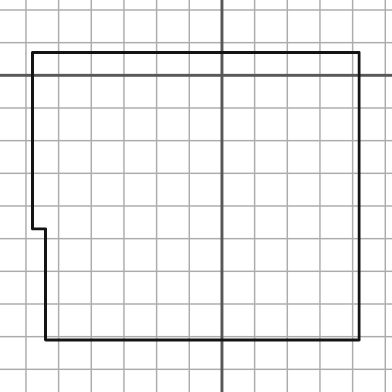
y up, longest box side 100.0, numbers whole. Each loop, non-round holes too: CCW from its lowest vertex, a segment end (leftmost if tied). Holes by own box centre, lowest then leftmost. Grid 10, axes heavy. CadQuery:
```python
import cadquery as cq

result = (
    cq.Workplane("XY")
    .moveTo(-54.0, -81.0)
    .lineTo(42.0, -81.0)
    .lineTo(42.0, 7.0)
    .lineTo(-58.0, 7.0)
    .lineTo(-58.0, -47.0)
    .lineTo(-54.0, -47.0)
    .close()
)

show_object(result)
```